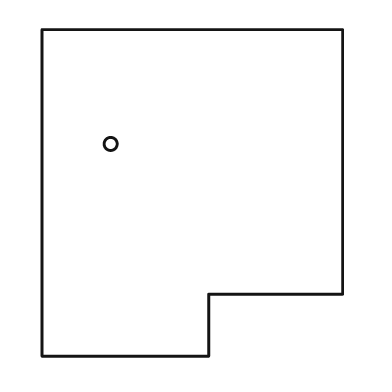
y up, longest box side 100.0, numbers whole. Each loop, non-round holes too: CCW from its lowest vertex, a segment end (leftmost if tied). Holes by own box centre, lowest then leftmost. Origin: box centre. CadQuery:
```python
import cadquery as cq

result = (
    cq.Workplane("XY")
    .moveTo(-46.0, -50.0)
    .lineTo(5.0, -50.0)
    .lineTo(5.0, -31.0)
    .lineTo(46.0, -31.0)
    .lineTo(46.0, 50.0)
    .lineTo(-46.0, 50.0)
    .close()
    .moveTo(-25.0, 15.0)
    .circle(2.0)
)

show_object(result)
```